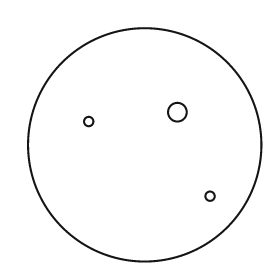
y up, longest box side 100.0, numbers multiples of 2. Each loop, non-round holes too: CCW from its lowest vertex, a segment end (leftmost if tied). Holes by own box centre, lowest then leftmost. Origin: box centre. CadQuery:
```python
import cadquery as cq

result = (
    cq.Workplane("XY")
    .moveTo(0.0, 0.0)
    .circle(50.0)
    .moveTo(28.0, -22.0)
    .circle(2.0)
    .moveTo(-24.0, 10.0)
    .circle(2.0)
    .moveTo(14.0, 14.0)
    .circle(4.0)
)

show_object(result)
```